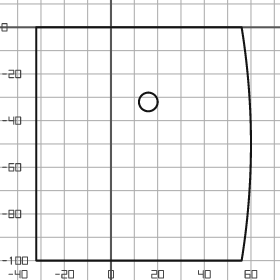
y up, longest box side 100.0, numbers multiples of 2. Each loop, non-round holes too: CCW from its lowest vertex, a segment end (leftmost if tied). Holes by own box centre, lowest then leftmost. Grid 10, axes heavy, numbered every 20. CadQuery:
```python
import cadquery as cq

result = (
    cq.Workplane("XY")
    .moveTo(-32.0, -100.0)
    .lineTo(56.0, -100.0)
    .threePointArc((60.0, -50.0), (56.0, 0.0))
    .lineTo(-32.0, 0.0)
    .close()
    .moveTo(16.0, -32.0)
    .circle(4.0)
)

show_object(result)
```